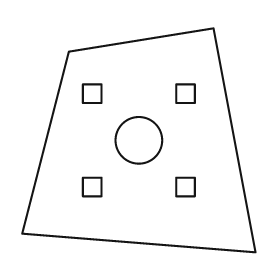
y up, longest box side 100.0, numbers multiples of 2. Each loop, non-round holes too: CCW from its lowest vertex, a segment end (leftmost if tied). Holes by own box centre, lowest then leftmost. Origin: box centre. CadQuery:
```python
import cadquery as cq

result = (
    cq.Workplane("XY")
    .moveTo(50.0, -48.0)
    .lineTo(32.0, 48.0)
    .lineTo(-30.0, 38.0)
    .lineTo(-50.0, -40.0)
    .close()
    .moveTo(-24.0, -24.0)
    .lineTo(-16.0, -24.0)
    .lineTo(-16.0, -16.0)
    .lineTo(-24.0, -16.0)
    .close()
    .moveTo(16.0, -24.0)
    .lineTo(24.0, -24.0)
    .lineTo(24.0, -16.0)
    .lineTo(16.0, -16.0)
    .close()
    .moveTo(0.0, 0.0)
    .circle(10.0)
    .moveTo(-24.0, 16.0)
    .lineTo(-16.0, 16.0)
    .lineTo(-16.0, 24.0)
    .lineTo(-24.0, 24.0)
    .close()
    .moveTo(16.0, 16.0)
    .lineTo(24.0, 16.0)
    .lineTo(24.0, 24.0)
    .lineTo(16.0, 24.0)
    .close()
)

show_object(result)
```